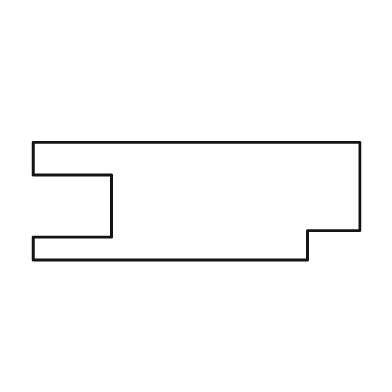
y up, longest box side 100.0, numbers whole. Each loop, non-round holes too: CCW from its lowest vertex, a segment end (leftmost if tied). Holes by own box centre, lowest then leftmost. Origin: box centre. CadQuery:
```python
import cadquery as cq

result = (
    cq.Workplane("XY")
    .moveTo(-50.0, -18.0)
    .lineTo(34.0, -18.0)
    .lineTo(34.0, -9.0)
    .lineTo(50.0, -9.0)
    .lineTo(50.0, 18.0)
    .lineTo(-50.0, 18.0)
    .lineTo(-50.0, 8.0)
    .lineTo(-26.0, 8.0)
    .lineTo(-26.0, -11.0)
    .lineTo(-50.0, -11.0)
    .close()
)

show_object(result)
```